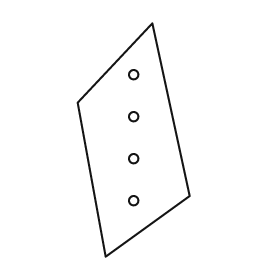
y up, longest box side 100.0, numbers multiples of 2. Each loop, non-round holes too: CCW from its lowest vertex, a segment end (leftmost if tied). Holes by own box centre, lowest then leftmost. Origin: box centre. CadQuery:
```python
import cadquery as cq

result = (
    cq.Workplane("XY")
    .moveTo(-12.0, -50.0)
    .lineTo(24.0, -24.0)
    .lineTo(8.0, 50.0)
    .lineTo(-24.0, 16.0)
    .close()
    .moveTo(0.0, -26.0)
    .circle(2.0)
    .moveTo(0.0, -8.0)
    .circle(2.0)
    .moveTo(0.0, 10.0)
    .circle(2.0)
    .moveTo(0.0, 28.0)
    .circle(2.0)
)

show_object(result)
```